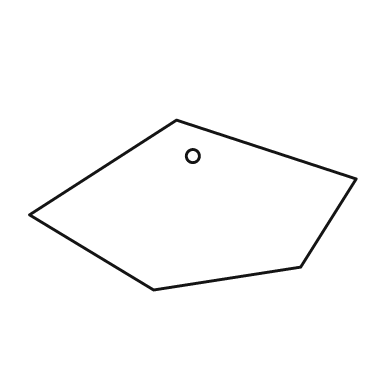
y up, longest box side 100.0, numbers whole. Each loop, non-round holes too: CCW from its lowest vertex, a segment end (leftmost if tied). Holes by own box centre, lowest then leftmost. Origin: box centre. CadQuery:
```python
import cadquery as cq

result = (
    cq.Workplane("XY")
    .moveTo(-12.0, -26.0)
    .lineTo(33.0, -19.0)
    .lineTo(50.0, 8.0)
    .lineTo(-5.0, 26.0)
    .lineTo(-50.0, -3.0)
    .close()
    .moveTo(0.0, 15.0)
    .circle(2.0)
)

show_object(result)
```